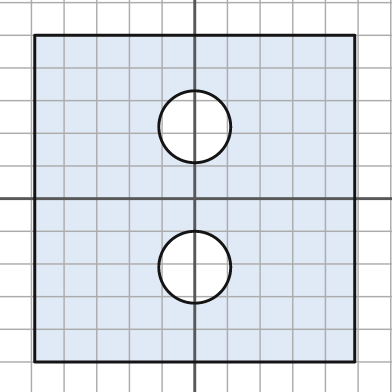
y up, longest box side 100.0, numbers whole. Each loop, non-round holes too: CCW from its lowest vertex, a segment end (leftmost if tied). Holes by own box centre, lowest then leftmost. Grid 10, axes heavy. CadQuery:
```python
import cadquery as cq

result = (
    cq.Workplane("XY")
    .moveTo(-49.0, -50.0)
    .lineTo(49.0, -50.0)
    .lineTo(49.0, 50.0)
    .lineTo(-49.0, 50.0)
    .close()
    .moveTo(0.0, -21.0)
    .circle(11.0)
    .moveTo(0.0, 22.0)
    .circle(11.0)
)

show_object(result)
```